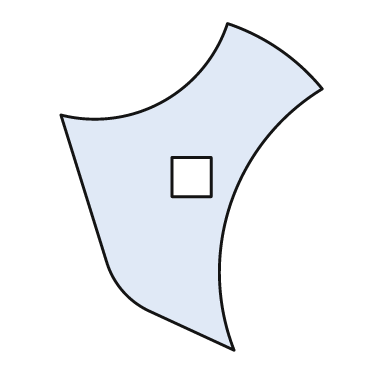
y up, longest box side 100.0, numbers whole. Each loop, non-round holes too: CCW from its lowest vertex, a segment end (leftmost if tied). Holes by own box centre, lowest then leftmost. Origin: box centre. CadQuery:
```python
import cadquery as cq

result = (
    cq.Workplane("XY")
    .moveTo(13.0, -50.0)
    .threePointArc((12.0, -5.0), (40.0, 30.0))
    .threePointArc((27.0, 42.0), (11.0, 50.0))
    .threePointArc((-9.0, 26.0), (-40.0, 22.0))
    .lineTo(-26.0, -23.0)
    .threePointArc((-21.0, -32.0), (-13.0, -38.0))
    .close()
    .moveTo(-6.0, -3.0)
    .lineTo(6.0, -3.0)
    .lineTo(6.0, 9.0)
    .lineTo(-6.0, 9.0)
    .close()
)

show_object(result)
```